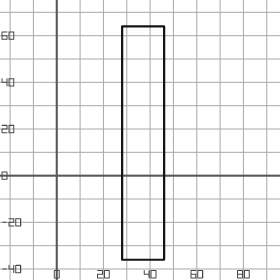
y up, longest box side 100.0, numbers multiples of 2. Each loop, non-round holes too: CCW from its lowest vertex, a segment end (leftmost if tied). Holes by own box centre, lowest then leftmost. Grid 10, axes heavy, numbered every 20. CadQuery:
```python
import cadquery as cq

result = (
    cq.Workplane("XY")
    .moveTo(28.0, -36.0)
    .lineTo(46.0, -36.0)
    .lineTo(46.0, 64.0)
    .lineTo(28.0, 64.0)
    .close()
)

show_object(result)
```